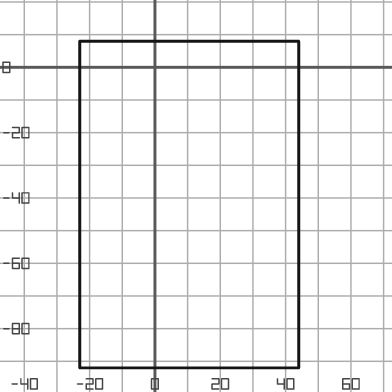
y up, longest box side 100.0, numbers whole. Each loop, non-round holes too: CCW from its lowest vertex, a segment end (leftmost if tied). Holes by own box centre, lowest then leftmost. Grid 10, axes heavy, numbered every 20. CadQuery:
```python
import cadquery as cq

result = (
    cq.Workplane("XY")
    .moveTo(-23.0, -92.0)
    .lineTo(44.0, -92.0)
    .lineTo(44.0, 8.0)
    .lineTo(-23.0, 8.0)
    .close()
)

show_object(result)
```